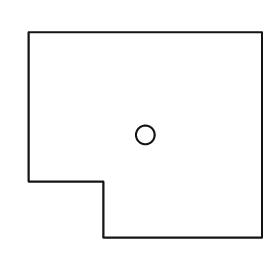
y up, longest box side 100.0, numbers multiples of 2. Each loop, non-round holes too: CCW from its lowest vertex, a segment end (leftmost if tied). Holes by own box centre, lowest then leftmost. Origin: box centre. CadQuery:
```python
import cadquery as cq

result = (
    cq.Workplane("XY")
    .moveTo(-18.0, -44.0)
    .lineTo(50.0, -44.0)
    .lineTo(50.0, 44.0)
    .lineTo(-50.0, 44.0)
    .lineTo(-50.0, -20.0)
    .lineTo(-18.0, -20.0)
    .close()
    .moveTo(0.0, 0.0)
    .circle(4.0)
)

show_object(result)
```